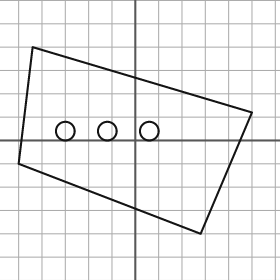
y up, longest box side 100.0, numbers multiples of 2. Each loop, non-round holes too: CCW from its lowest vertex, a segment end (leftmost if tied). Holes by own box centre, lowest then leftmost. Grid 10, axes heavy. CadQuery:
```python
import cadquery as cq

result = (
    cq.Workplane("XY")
    .moveTo(28.0, -40.0)
    .lineTo(50.0, 12.0)
    .lineTo(-44.0, 40.0)
    .lineTo(-50.0, -10.0)
    .close()
    .moveTo(-30.0, 4.0)
    .circle(4.0)
    .moveTo(-12.0, 4.0)
    .circle(4.0)
    .moveTo(6.0, 4.0)
    .circle(4.0)
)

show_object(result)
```